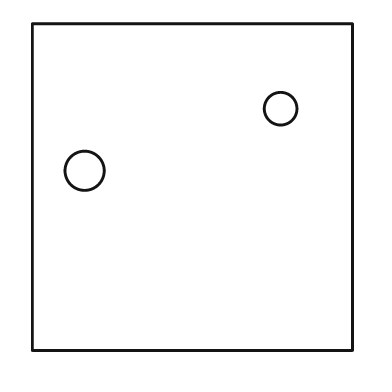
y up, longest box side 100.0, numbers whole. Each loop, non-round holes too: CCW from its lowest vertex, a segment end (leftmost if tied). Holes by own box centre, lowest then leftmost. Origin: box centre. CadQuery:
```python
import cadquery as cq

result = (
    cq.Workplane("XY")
    .moveTo(-49.0, -50.0)
    .lineTo(49.0, -50.0)
    .lineTo(49.0, 50.0)
    .lineTo(-49.0, 50.0)
    .close()
    .moveTo(-33.0, 5.0)
    .circle(6.0)
    .moveTo(27.0, 24.0)
    .circle(5.0)
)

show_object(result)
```